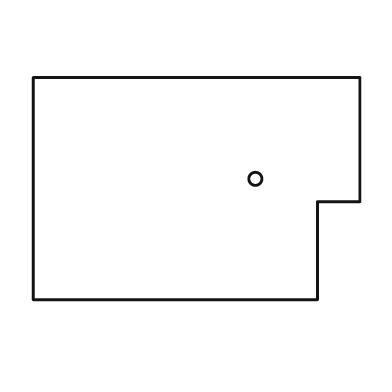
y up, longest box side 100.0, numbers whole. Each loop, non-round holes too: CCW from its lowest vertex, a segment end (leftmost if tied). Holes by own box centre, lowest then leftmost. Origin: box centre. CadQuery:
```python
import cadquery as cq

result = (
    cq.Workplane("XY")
    .moveTo(-50.0, -34.0)
    .lineTo(37.0, -34.0)
    .lineTo(37.0, -4.0)
    .lineTo(50.0, -4.0)
    .lineTo(50.0, 34.0)
    .lineTo(-50.0, 34.0)
    .close()
    .moveTo(18.0, 3.0)
    .circle(2.0)
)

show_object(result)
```